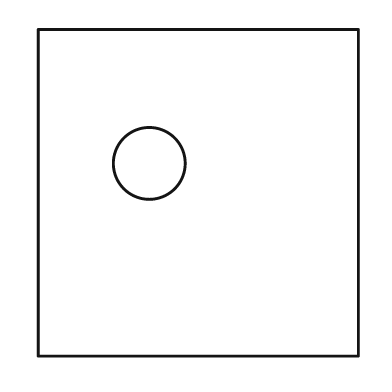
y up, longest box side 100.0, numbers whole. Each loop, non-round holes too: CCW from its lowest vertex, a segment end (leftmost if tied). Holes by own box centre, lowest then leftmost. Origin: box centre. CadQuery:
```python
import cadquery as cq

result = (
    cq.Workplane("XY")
    .moveTo(-49.0, -50.0)
    .lineTo(49.0, -50.0)
    .lineTo(49.0, 50.0)
    .lineTo(-49.0, 50.0)
    .close()
    .moveTo(-15.0, 9.0)
    .circle(11.0)
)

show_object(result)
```